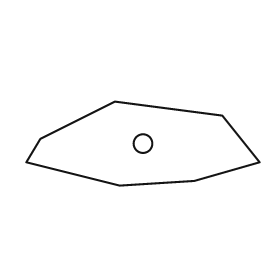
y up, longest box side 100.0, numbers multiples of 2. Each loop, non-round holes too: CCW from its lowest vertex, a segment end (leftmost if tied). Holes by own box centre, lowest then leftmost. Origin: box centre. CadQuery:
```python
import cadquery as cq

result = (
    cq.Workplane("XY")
    .moveTo(-10.0, -18.0)
    .lineTo(22.0, -16.0)
    .lineTo(50.0, -8.0)
    .lineTo(34.0, 12.0)
    .lineTo(-12.0, 18.0)
    .lineTo(-44.0, 2.0)
    .lineTo(-50.0, -8.0)
    .close()
    .moveTo(0.0, 0.0)
    .circle(4.0)
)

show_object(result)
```